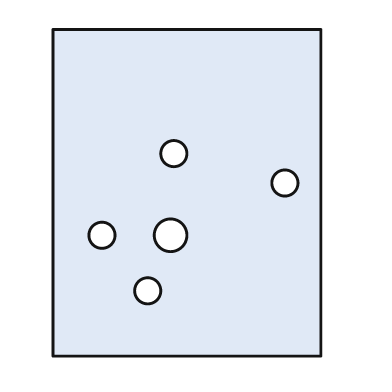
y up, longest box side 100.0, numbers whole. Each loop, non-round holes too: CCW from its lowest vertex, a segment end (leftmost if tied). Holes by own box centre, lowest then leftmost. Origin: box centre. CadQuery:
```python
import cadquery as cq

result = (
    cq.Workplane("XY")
    .moveTo(-41.0, -50.0)
    .lineTo(41.0, -50.0)
    .lineTo(41.0, 50.0)
    .lineTo(-41.0, 50.0)
    .close()
    .moveTo(-12.0, -30.0)
    .circle(4.0)
    .moveTo(-26.0, -13.0)
    .circle(4.0)
    .moveTo(-5.0, -13.0)
    .circle(5.0)
    .moveTo(30.0, 3.0)
    .circle(4.0)
    .moveTo(-4.0, 12.0)
    .circle(4.0)
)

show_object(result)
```